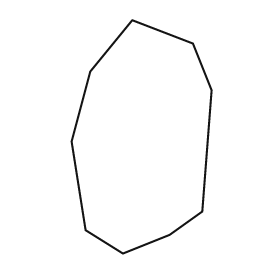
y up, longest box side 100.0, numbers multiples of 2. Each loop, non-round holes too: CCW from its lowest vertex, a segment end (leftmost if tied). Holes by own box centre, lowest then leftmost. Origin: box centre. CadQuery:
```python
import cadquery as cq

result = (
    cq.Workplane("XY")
    .moveTo(-8.0, -50.0)
    .lineTo(12.0, -42.0)
    .lineTo(26.0, -32.0)
    .lineTo(30.0, 20.0)
    .lineTo(22.0, 40.0)
    .lineTo(-4.0, 50.0)
    .lineTo(-22.0, 28.0)
    .lineTo(-30.0, -2.0)
    .lineTo(-24.0, -40.0)
    .close()
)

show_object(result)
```